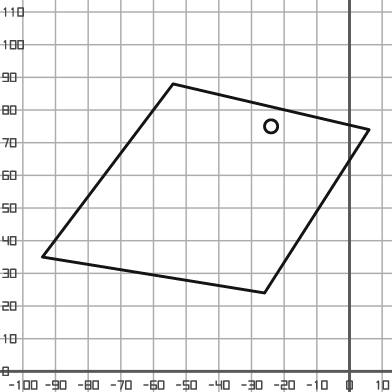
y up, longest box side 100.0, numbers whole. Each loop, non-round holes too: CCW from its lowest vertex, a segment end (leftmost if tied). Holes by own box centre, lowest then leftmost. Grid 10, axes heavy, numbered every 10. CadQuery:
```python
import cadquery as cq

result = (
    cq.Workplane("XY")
    .moveTo(-26.0, 24.0)
    .lineTo(6.0, 74.0)
    .lineTo(-54.0, 88.0)
    .lineTo(-94.0, 35.0)
    .close()
    .moveTo(-24.0, 75.0)
    .circle(2.0)
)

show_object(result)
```